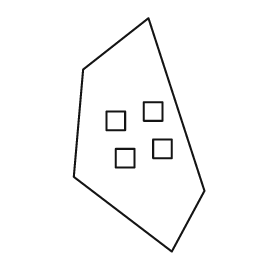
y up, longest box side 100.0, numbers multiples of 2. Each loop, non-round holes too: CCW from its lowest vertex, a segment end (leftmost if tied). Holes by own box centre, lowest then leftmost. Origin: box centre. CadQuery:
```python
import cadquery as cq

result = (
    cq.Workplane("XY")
    .moveTo(14.0, -50.0)
    .lineTo(28.0, -24.0)
    .lineTo(4.0, 50.0)
    .lineTo(-24.0, 28.0)
    .lineTo(-28.0, -18.0)
    .close()
    .moveTo(-10.0, -14.0)
    .lineTo(-2.0, -14.0)
    .lineTo(-2.0, -6.0)
    .lineTo(-10.0, -6.0)
    .close()
    .moveTo(6.0, -10.0)
    .lineTo(14.0, -10.0)
    .lineTo(14.0, -2.0)
    .lineTo(6.0, -2.0)
    .close()
    .moveTo(-14.0, 2.0)
    .lineTo(-6.0, 2.0)
    .lineTo(-6.0, 10.0)
    .lineTo(-14.0, 10.0)
    .close()
    .moveTo(2.0, 6.0)
    .lineTo(10.0, 6.0)
    .lineTo(10.0, 14.0)
    .lineTo(2.0, 14.0)
    .close()
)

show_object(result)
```